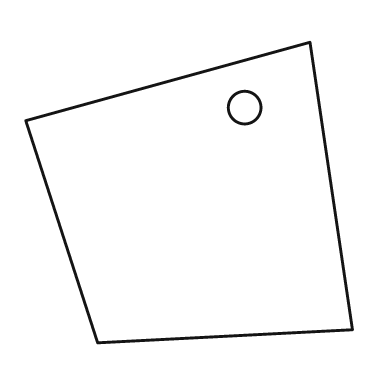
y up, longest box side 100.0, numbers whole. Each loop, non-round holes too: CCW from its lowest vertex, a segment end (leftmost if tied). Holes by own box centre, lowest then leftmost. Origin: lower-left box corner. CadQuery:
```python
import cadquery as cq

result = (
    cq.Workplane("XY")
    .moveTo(22.0, 0.0)
    .lineTo(100.0, 4.0)
    .lineTo(87.0, 92.0)
    .lineTo(0.0, 68.0)
    .close()
    .moveTo(67.0, 72.0)
    .circle(5.0)
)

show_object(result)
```